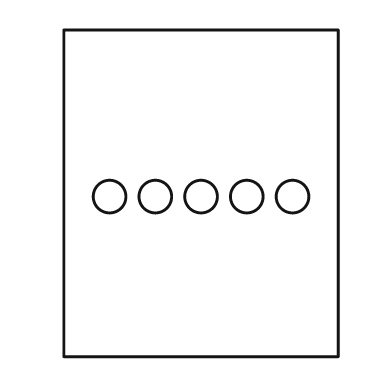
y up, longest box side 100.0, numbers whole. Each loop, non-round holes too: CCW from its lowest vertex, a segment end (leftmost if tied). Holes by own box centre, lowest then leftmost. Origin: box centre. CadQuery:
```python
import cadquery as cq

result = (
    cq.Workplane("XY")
    .moveTo(-42.0, -50.0)
    .lineTo(42.0, -50.0)
    .lineTo(42.0, 50.0)
    .lineTo(-42.0, 50.0)
    .close()
    .moveTo(-28.0, -1.0)
    .circle(5.0)
    .moveTo(-14.0, -1.0)
    .circle(5.0)
    .moveTo(0.0, -1.0)
    .circle(5.0)
    .moveTo(14.0, -1.0)
    .circle(5.0)
    .moveTo(28.0, -1.0)
    .circle(5.0)
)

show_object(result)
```